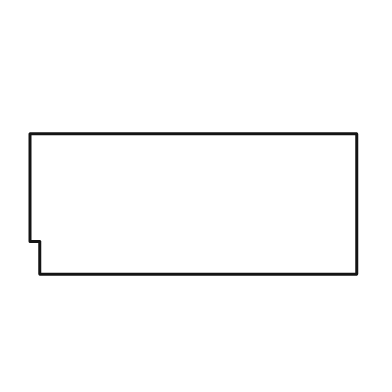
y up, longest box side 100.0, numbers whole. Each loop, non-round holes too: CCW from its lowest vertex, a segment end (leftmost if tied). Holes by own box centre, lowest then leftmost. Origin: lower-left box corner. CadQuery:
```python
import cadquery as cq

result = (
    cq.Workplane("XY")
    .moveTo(3.0, 0.0)
    .lineTo(100.0, 0.0)
    .lineTo(100.0, 43.0)
    .lineTo(0.0, 43.0)
    .lineTo(0.0, 10.0)
    .lineTo(3.0, 10.0)
    .close()
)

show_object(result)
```